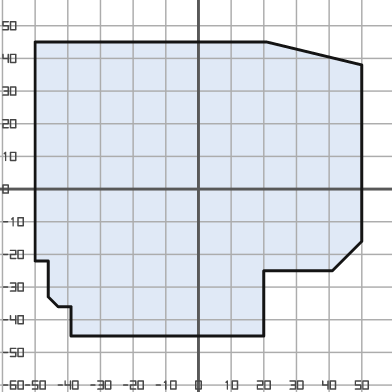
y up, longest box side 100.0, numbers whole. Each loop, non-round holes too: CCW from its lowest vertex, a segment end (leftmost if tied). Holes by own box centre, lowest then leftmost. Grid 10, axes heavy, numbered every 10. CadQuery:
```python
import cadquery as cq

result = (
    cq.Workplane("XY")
    .moveTo(-39.0, -45.0)
    .lineTo(20.0, -45.0)
    .lineTo(20.0, -25.0)
    .lineTo(41.0, -25.0)
    .lineTo(50.0, -16.0)
    .lineTo(50.0, 38.0)
    .lineTo(21.0, 45.0)
    .lineTo(-50.0, 45.0)
    .lineTo(-50.0, -22.0)
    .lineTo(-46.0, -22.0)
    .lineTo(-46.0, -33.0)
    .lineTo(-43.0, -36.0)
    .lineTo(-39.0, -36.0)
    .close()
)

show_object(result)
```